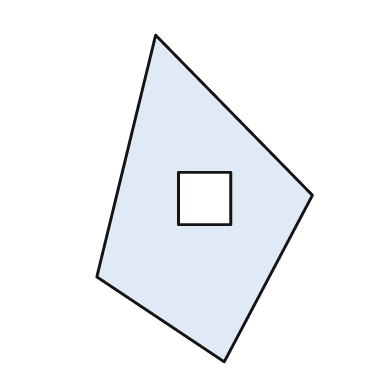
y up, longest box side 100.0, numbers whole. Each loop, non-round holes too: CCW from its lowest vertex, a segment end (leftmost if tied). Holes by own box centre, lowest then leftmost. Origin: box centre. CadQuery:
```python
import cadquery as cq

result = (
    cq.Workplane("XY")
    .moveTo(6.0, -50.0)
    .lineTo(33.0, 1.0)
    .lineTo(-15.0, 50.0)
    .lineTo(-33.0, -24.0)
    .close()
    .moveTo(-8.0, -8.0)
    .lineTo(8.0, -8.0)
    .lineTo(8.0, 8.0)
    .lineTo(-8.0, 8.0)
    .close()
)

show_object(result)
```